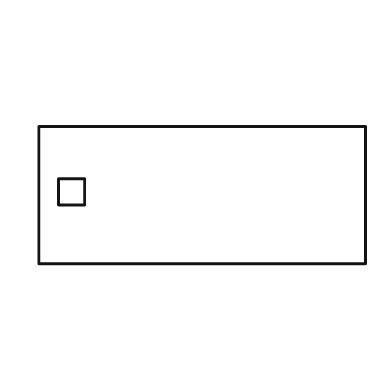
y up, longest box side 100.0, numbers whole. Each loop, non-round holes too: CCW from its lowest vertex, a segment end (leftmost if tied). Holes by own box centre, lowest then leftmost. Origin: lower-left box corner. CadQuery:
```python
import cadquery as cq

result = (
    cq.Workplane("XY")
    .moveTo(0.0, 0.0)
    .lineTo(100.0, 0.0)
    .lineTo(100.0, 42.0)
    .lineTo(0.0, 42.0)
    .close()
    .moveTo(6.0, 18.0)
    .lineTo(14.0, 18.0)
    .lineTo(14.0, 26.0)
    .lineTo(6.0, 26.0)
    .close()
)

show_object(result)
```